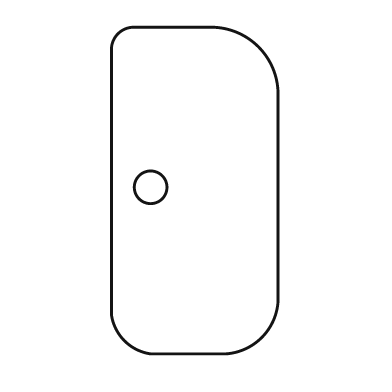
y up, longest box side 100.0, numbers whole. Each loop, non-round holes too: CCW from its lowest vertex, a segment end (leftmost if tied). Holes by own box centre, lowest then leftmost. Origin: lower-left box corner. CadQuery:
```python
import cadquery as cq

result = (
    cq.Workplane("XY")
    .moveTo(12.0, 0.0)
    .lineTo(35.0, 0.0)
    .threePointArc((46.0, 5.0), (51.0, 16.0))
    .lineTo(51.0, 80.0)
    .threePointArc((45.0, 94.0), (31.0, 100.0))
    .lineTo(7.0, 100.0)
    .threePointArc((2.0, 98.0), (0.0, 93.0))
    .lineTo(0.0, 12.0)
    .threePointArc((4.0, 4.0), (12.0, 0.0))
    .close()
    .moveTo(12.0, 51.0)
    .circle(5.0)
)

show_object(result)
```